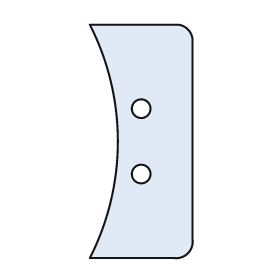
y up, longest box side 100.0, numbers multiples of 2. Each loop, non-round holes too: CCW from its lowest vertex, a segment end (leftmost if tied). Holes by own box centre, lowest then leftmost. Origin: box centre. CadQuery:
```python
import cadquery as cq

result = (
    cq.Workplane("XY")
    .moveTo(-22.0, -50.0)
    .lineTo(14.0, -50.0)
    .threePointArc((20.0, -48.0), (22.0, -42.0))
    .lineTo(22.0, 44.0)
    .threePointArc((20.0, 48.0), (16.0, 50.0))
    .lineTo(-22.0, 50.0)
    .threePointArc((-10.0, 0.0), (-22.0, -50.0))
    .close()
    .moveTo(0.0, -14.0)
    .circle(4.0)
    .moveTo(0.0, 14.0)
    .circle(4.0)
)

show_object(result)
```